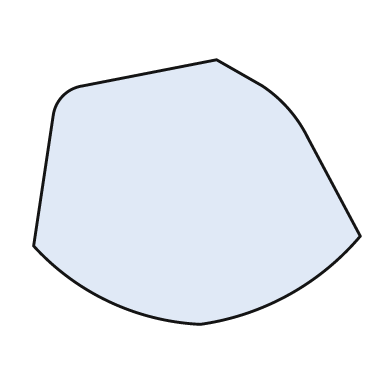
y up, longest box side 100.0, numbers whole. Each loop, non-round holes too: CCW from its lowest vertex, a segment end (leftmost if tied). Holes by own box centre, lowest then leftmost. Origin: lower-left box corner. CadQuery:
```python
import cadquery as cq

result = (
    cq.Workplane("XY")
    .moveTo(51.0, 0.0)
    .threePointArc((78.0, 9.0), (100.0, 27.0))
    .lineTo(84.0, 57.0)
    .threePointArc((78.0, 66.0), (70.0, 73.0))
    .lineTo(56.0, 81.0)
    .lineTo(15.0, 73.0)
    .threePointArc((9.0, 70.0), (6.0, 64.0))
    .lineTo(0.0, 24.0)
    .threePointArc((23.0, 7.0), (51.0, 0.0))
    .close()
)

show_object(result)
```